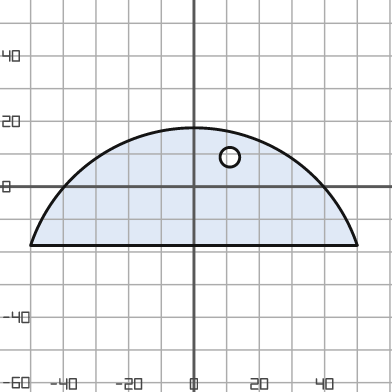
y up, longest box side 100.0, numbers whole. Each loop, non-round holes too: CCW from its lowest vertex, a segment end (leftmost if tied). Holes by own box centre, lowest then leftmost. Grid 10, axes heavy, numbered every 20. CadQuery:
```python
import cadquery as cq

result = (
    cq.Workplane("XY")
    .moveTo(-50.0, -18.0)
    .lineTo(50.0, -18.0)
    .threePointArc((0.0, 18.0), (-50.0, -18.0))
    .close()
    .moveTo(11.0, 9.0)
    .circle(3.0)
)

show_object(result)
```